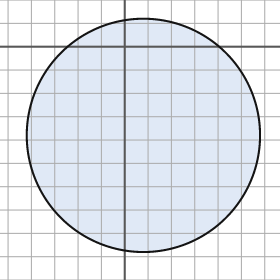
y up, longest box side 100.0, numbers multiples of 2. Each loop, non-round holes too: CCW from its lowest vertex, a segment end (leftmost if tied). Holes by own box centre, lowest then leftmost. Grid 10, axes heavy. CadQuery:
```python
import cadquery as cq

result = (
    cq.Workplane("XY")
    .moveTo(8.0, -38.0)
    .circle(50.0)
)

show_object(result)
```